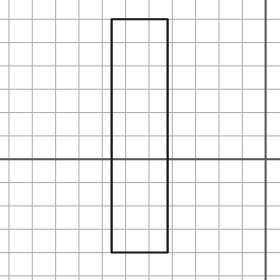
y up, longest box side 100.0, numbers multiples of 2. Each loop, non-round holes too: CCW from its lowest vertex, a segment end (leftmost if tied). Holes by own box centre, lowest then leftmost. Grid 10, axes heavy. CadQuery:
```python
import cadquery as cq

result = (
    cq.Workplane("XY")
    .moveTo(-66.0, -40.0)
    .lineTo(-42.0, -40.0)
    .lineTo(-42.0, 60.0)
    .lineTo(-66.0, 60.0)
    .close()
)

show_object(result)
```